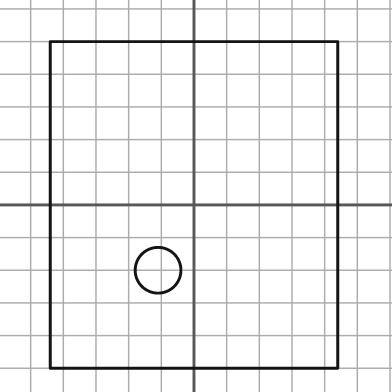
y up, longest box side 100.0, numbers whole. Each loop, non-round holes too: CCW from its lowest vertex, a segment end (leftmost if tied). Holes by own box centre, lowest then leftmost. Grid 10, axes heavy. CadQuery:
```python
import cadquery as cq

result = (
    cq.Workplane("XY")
    .moveTo(-44.0, -50.0)
    .lineTo(44.0, -50.0)
    .lineTo(44.0, 50.0)
    .lineTo(-44.0, 50.0)
    .close()
    .moveTo(-11.0, -20.0)
    .circle(7.0)
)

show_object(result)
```